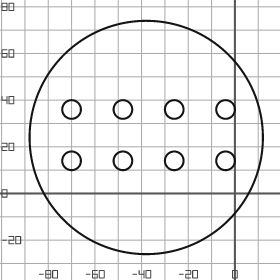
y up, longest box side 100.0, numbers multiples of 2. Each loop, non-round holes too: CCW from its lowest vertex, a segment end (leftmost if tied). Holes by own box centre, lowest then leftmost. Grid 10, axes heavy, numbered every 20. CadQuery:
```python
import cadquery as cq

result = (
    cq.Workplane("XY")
    .moveTo(-38.0, 24.0)
    .circle(50.0)
    .moveTo(-70.0, 14.0)
    .circle(4.0)
    .moveTo(-48.0, 14.0)
    .circle(4.0)
    .moveTo(-26.0, 14.0)
    .circle(4.0)
    .moveTo(-4.0, 14.0)
    .circle(4.0)
    .moveTo(-70.0, 36.0)
    .circle(4.0)
    .moveTo(-48.0, 36.0)
    .circle(4.0)
    .moveTo(-26.0, 36.0)
    .circle(4.0)
    .moveTo(-4.0, 36.0)
    .circle(4.0)
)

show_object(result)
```